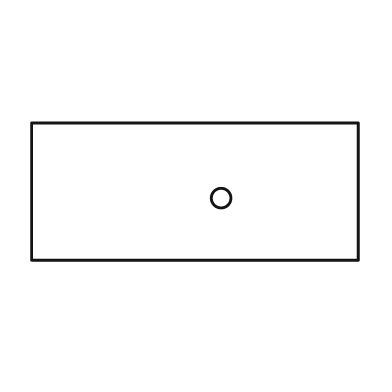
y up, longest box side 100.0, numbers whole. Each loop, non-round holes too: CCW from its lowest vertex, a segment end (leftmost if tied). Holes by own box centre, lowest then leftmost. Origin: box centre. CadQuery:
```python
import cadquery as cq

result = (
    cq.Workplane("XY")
    .moveTo(-50.0, -21.0)
    .lineTo(50.0, -21.0)
    .lineTo(50.0, 21.0)
    .lineTo(-50.0, 21.0)
    .close()
    .moveTo(8.0, -2.0)
    .circle(3.0)
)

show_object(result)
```